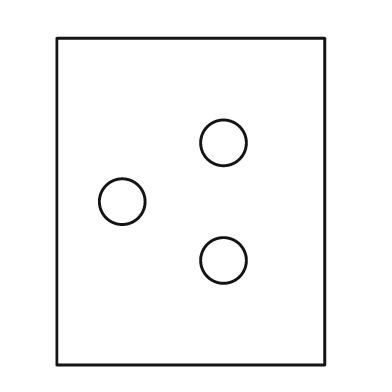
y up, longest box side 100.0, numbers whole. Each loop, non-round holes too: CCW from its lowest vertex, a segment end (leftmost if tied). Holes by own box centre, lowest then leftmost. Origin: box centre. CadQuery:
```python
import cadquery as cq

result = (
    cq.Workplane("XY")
    .moveTo(-41.0, -50.0)
    .lineTo(41.0, -50.0)
    .lineTo(41.0, 50.0)
    .lineTo(-41.0, 50.0)
    .close()
    .moveTo(10.0, -18.0)
    .circle(7.0)
    .moveTo(-21.0, 0.0)
    .circle(7.0)
    .moveTo(10.0, 18.0)
    .circle(7.0)
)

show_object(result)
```